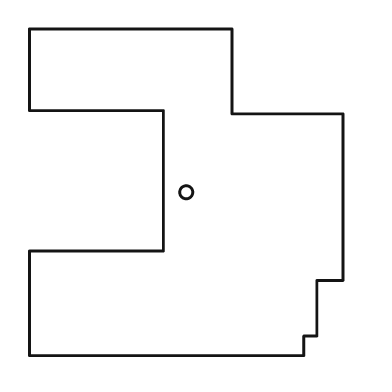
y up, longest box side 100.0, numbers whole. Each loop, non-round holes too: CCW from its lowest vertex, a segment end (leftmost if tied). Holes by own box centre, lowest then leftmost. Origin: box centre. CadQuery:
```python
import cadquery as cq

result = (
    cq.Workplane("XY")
    .moveTo(-48.0, -50.0)
    .lineTo(36.0, -50.0)
    .lineTo(36.0, -44.0)
    .lineTo(40.0, -44.0)
    .lineTo(40.0, -27.0)
    .lineTo(48.0, -27.0)
    .lineTo(48.0, 24.0)
    .lineTo(14.0, 24.0)
    .lineTo(14.0, 50.0)
    .lineTo(-48.0, 50.0)
    .lineTo(-48.0, 25.0)
    .lineTo(-7.0, 25.0)
    .lineTo(-7.0, -18.0)
    .lineTo(-48.0, -18.0)
    .close()
    .moveTo(0.0, 0.0)
    .circle(2.0)
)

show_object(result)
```